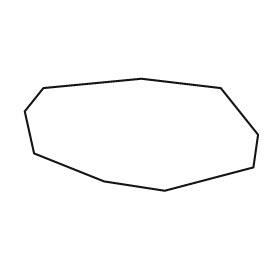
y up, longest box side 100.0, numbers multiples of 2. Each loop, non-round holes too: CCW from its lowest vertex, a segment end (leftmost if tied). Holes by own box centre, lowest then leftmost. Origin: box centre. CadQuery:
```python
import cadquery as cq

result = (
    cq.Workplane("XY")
    .moveTo(10.0, -24.0)
    .lineTo(48.0, -14.0)
    .lineTo(50.0, 0.0)
    .lineTo(34.0, 20.0)
    .lineTo(0.0, 24.0)
    .lineTo(-42.0, 20.0)
    .lineTo(-50.0, 10.0)
    .lineTo(-46.0, -8.0)
    .lineTo(-16.0, -20.0)
    .close()
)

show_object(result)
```